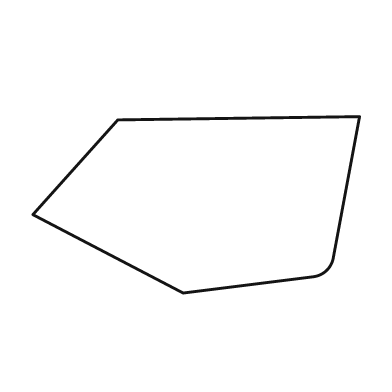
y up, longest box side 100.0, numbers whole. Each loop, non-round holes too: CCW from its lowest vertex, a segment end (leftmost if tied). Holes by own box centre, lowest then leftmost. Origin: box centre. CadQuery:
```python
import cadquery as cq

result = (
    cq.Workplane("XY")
    .moveTo(-4.0, -27.0)
    .lineTo(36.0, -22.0)
    .threePointArc((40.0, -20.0), (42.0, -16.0))
    .lineTo(50.0, 27.0)
    .lineTo(-24.0, 26.0)
    .lineTo(-50.0, -3.0)
    .close()
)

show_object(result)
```